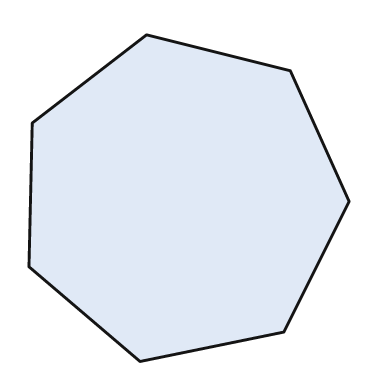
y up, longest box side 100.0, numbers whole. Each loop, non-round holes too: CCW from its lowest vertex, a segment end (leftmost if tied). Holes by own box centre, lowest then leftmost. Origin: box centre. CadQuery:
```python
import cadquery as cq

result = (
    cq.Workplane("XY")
    .moveTo(-15.0, -50.0)
    .lineTo(29.0, -41.0)
    .lineTo(49.0, -1.0)
    .lineTo(31.0, 39.0)
    .lineTo(-13.0, 50.0)
    .lineTo(-48.0, 23.0)
    .lineTo(-49.0, -21.0)
    .close()
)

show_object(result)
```